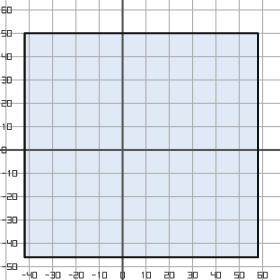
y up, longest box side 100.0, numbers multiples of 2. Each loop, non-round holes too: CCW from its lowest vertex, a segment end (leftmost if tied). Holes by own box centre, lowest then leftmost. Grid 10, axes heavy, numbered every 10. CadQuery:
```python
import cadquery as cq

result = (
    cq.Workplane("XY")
    .moveTo(-42.0, -46.0)
    .lineTo(58.0, -46.0)
    .lineTo(58.0, 50.0)
    .lineTo(-42.0, 50.0)
    .close()
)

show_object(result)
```